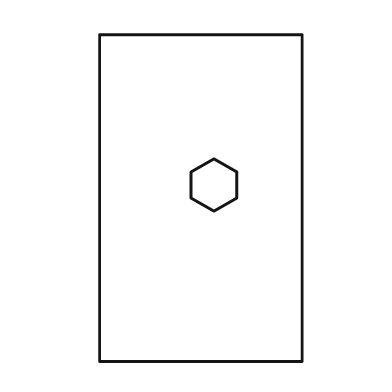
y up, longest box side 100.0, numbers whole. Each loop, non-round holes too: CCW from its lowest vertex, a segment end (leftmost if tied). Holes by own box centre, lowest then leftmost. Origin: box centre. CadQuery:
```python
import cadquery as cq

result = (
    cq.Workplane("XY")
    .moveTo(-31.0, -50.0)
    .lineTo(31.0, -50.0)
    .lineTo(31.0, 50.0)
    .lineTo(-31.0, 50.0)
    .close()
    .moveTo(4.0, -4.0)
    .lineTo(11.0, 0.0)
    .lineTo(11.0, 8.0)
    .lineTo(4.0, 12.0)
    .lineTo(-3.0, 8.0)
    .lineTo(-3.0, 0.0)
    .close()
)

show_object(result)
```